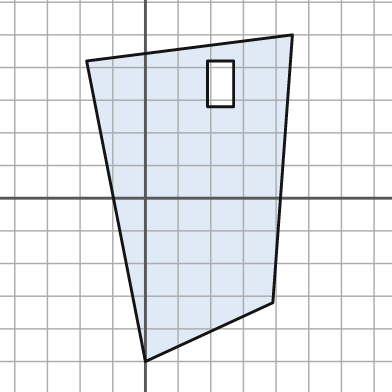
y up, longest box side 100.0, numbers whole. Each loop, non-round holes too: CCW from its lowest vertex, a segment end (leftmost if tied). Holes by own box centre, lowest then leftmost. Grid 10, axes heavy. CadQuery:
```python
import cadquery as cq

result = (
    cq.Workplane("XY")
    .moveTo(0.0, -50.0)
    .lineTo(39.0, -32.0)
    .lineTo(45.0, 50.0)
    .lineTo(-18.0, 42.0)
    .close()
    .moveTo(19.0, 28.0)
    .lineTo(27.0, 28.0)
    .lineTo(27.0, 42.0)
    .lineTo(19.0, 42.0)
    .close()
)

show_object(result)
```